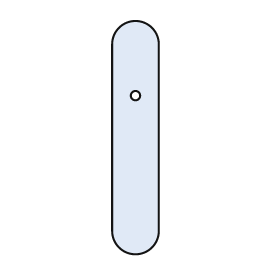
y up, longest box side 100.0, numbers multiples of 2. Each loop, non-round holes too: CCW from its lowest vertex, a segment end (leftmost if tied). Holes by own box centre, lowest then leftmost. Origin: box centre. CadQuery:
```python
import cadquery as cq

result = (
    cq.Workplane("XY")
    .moveTo(-10.0, -40.0)
    .threePointArc((0.0, -50.0), (10.0, -40.0))
    .lineTo(10.0, 40.0)
    .threePointArc((0.0, 50.0), (-10.0, 40.0))
    .close()
    .moveTo(0.0, 18.0)
    .circle(2.0)
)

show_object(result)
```